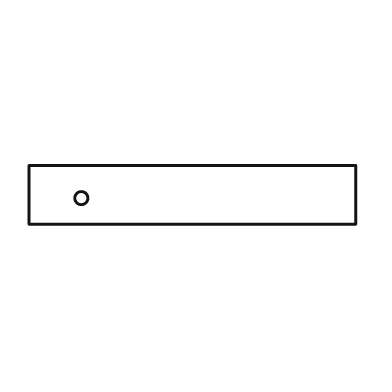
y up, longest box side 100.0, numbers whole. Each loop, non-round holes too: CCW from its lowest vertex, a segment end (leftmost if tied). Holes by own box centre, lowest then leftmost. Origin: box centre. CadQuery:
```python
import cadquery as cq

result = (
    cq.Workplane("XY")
    .moveTo(-50.0, -9.0)
    .lineTo(50.0, -9.0)
    .lineTo(50.0, 9.0)
    .lineTo(-50.0, 9.0)
    .close()
    .moveTo(-34.0, -1.0)
    .circle(2.0)
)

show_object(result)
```